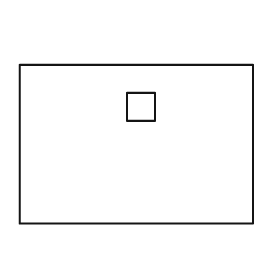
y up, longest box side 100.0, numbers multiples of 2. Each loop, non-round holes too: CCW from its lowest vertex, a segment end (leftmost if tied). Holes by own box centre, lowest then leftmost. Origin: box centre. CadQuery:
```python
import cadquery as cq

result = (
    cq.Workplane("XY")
    .moveTo(-50.0, -34.0)
    .lineTo(50.0, -34.0)
    .lineTo(50.0, 34.0)
    .lineTo(-50.0, 34.0)
    .close()
    .moveTo(-4.0, 10.0)
    .lineTo(8.0, 10.0)
    .lineTo(8.0, 22.0)
    .lineTo(-4.0, 22.0)
    .close()
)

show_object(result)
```